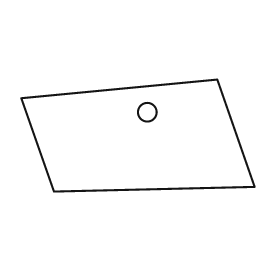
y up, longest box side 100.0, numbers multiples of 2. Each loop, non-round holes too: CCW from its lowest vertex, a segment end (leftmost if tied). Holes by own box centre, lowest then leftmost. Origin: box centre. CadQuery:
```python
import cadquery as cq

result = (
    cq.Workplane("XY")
    .moveTo(-36.0, -24.0)
    .lineTo(50.0, -22.0)
    .lineTo(34.0, 24.0)
    .lineTo(-50.0, 16.0)
    .close()
    .moveTo(4.0, 10.0)
    .circle(4.0)
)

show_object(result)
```